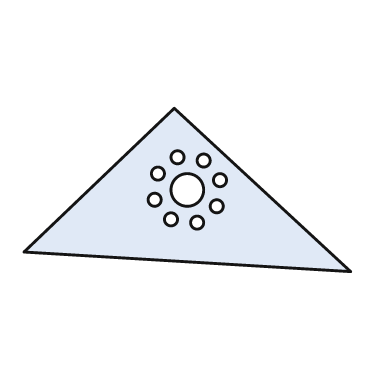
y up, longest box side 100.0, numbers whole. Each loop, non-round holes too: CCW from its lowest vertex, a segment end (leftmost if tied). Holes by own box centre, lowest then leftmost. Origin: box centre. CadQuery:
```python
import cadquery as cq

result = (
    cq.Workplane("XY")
    .moveTo(50.0, -25.0)
    .lineTo(-4.0, 25.0)
    .lineTo(-50.0, -19.0)
    .close()
    .moveTo(3.0, -10.0)
    .circle(2.0)
    .moveTo(-5.0, -9.0)
    .circle(2.0)
    .moveTo(9.0, -5.0)
    .circle(2.0)
    .moveTo(-10.0, -3.0)
    .circle(2.0)
    .moveTo(0.0, 0.0)
    .circle(5.0)
    .moveTo(10.0, 3.0)
    .circle(2.0)
    .moveTo(-9.0, 5.0)
    .circle(2.0)
    .moveTo(5.0, 9.0)
    .circle(2.0)
    .moveTo(-3.0, 10.0)
    .circle(2.0)
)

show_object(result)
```